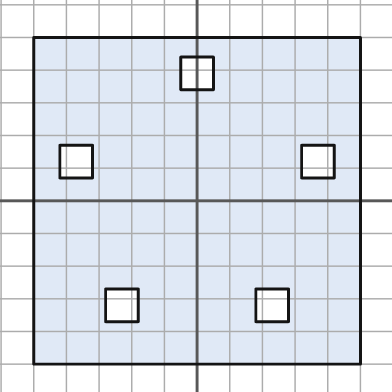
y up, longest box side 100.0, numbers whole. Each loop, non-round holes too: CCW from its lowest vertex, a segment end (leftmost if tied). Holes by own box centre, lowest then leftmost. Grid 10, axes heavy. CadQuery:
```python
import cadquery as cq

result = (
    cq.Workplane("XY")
    .moveTo(-50.0, -50.0)
    .lineTo(50.0, -50.0)
    .lineTo(50.0, 50.0)
    .lineTo(-50.0, 50.0)
    .close()
    .moveTo(-28.0, -37.0)
    .lineTo(-18.0, -37.0)
    .lineTo(-18.0, -27.0)
    .lineTo(-28.0, -27.0)
    .close()
    .moveTo(18.0, -37.0)
    .lineTo(28.0, -37.0)
    .lineTo(28.0, -27.0)
    .lineTo(18.0, -27.0)
    .close()
    .moveTo(-42.0, 7.0)
    .lineTo(-32.0, 7.0)
    .lineTo(-32.0, 17.0)
    .lineTo(-42.0, 17.0)
    .close()
    .moveTo(32.0, 7.0)
    .lineTo(42.0, 7.0)
    .lineTo(42.0, 17.0)
    .lineTo(32.0, 17.0)
    .close()
    .moveTo(-5.0, 34.0)
    .lineTo(5.0, 34.0)
    .lineTo(5.0, 44.0)
    .lineTo(-5.0, 44.0)
    .close()
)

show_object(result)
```